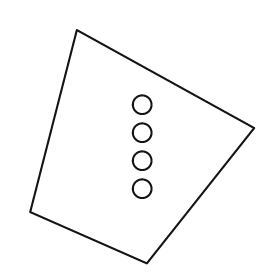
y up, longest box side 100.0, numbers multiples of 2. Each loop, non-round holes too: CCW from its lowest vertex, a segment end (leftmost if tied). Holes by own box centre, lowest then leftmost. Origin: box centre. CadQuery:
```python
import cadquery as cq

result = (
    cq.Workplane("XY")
    .moveTo(2.0, -50.0)
    .lineTo(48.0, 8.0)
    .lineTo(-28.0, 50.0)
    .lineTo(-48.0, -28.0)
    .close()
    .moveTo(0.0, -18.0)
    .circle(4.0)
    .moveTo(0.0, -6.0)
    .circle(4.0)
    .moveTo(0.0, 6.0)
    .circle(4.0)
    .moveTo(0.0, 18.0)
    .circle(4.0)
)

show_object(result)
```